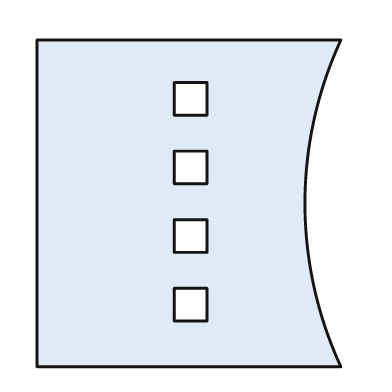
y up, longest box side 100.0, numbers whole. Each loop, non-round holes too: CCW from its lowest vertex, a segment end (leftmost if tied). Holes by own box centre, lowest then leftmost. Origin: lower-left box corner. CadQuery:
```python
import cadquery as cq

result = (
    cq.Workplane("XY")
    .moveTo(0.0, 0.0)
    .lineTo(93.0, 0.0)
    .threePointArc((82.0, 50.0), (93.0, 100.0))
    .lineTo(0.0, 100.0)
    .close()
    .moveTo(42.0, 14.0)
    .lineTo(52.0, 14.0)
    .lineTo(52.0, 24.0)
    .lineTo(42.0, 24.0)
    .close()
    .moveTo(42.0, 35.0)
    .lineTo(52.0, 35.0)
    .lineTo(52.0, 45.0)
    .lineTo(42.0, 45.0)
    .close()
    .moveTo(42.0, 56.0)
    .lineTo(52.0, 56.0)
    .lineTo(52.0, 66.0)
    .lineTo(42.0, 66.0)
    .close()
    .moveTo(42.0, 77.0)
    .lineTo(52.0, 77.0)
    .lineTo(52.0, 87.0)
    .lineTo(42.0, 87.0)
    .close()
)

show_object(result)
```